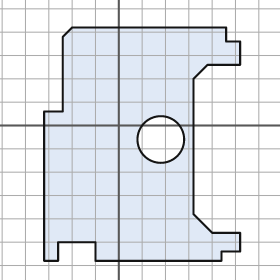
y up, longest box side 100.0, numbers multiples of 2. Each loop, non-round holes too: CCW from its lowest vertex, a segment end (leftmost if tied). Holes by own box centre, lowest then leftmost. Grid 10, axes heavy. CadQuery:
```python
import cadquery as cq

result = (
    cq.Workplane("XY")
    .moveTo(-32.0, -58.0)
    .lineTo(-26.0, -58.0)
    .lineTo(-26.0, -50.0)
    .lineTo(-10.0, -50.0)
    .lineTo(-10.0, -58.0)
    .lineTo(44.0, -58.0)
    .lineTo(44.0, -54.0)
    .lineTo(52.0, -54.0)
    .lineTo(52.0, -46.0)
    .lineTo(40.0, -46.0)
    .lineTo(32.0, -38.0)
    .lineTo(32.0, 20.0)
    .lineTo(38.0, 26.0)
    .lineTo(52.0, 26.0)
    .lineTo(52.0, 36.0)
    .lineTo(46.0, 36.0)
    .lineTo(46.0, 42.0)
    .lineTo(-20.0, 42.0)
    .lineTo(-24.0, 38.0)
    .lineTo(-24.0, 6.0)
    .lineTo(-32.0, 6.0)
    .close()
    .moveTo(18.0, -6.0)
    .circle(10.0)
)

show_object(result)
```